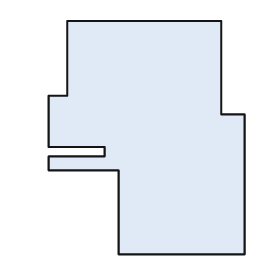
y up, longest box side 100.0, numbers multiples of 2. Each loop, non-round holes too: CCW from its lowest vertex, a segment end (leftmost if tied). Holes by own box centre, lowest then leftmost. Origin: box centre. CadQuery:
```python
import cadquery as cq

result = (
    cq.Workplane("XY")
    .moveTo(-12.0, -50.0)
    .lineTo(42.0, -50.0)
    .lineTo(42.0, 10.0)
    .lineTo(32.0, 10.0)
    .lineTo(32.0, 50.0)
    .lineTo(-34.0, 50.0)
    .lineTo(-34.0, 18.0)
    .lineTo(-42.0, 18.0)
    .lineTo(-42.0, -4.0)
    .lineTo(-18.0, -4.0)
    .lineTo(-18.0, -8.0)
    .lineTo(-42.0, -8.0)
    .lineTo(-42.0, -14.0)
    .lineTo(-12.0, -14.0)
    .close()
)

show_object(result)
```